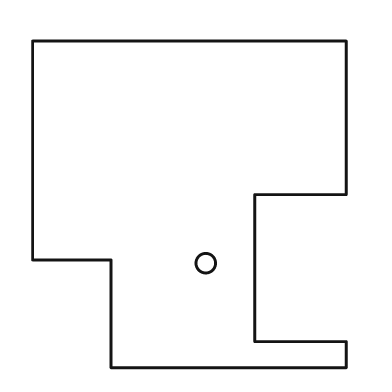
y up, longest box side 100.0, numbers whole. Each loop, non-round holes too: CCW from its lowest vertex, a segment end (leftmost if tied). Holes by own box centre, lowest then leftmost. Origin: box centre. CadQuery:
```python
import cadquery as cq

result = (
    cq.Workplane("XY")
    .moveTo(-24.0, -50.0)
    .lineTo(48.0, -50.0)
    .lineTo(48.0, -42.0)
    .lineTo(20.0, -42.0)
    .lineTo(20.0, 3.0)
    .lineTo(48.0, 3.0)
    .lineTo(48.0, 50.0)
    .lineTo(-48.0, 50.0)
    .lineTo(-48.0, -17.0)
    .lineTo(-24.0, -17.0)
    .close()
    .moveTo(5.0, -18.0)
    .circle(3.0)
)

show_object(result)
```